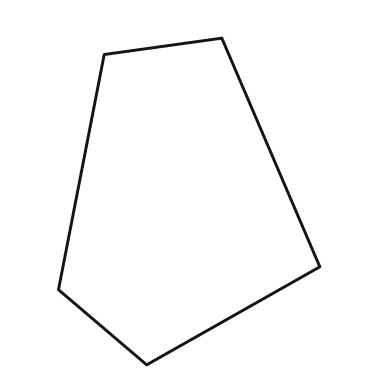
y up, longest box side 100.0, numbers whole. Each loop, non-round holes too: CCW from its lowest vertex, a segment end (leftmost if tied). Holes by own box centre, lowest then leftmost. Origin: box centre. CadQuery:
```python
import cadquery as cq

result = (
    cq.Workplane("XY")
    .moveTo(-13.0, -50.0)
    .lineTo(40.0, -20.0)
    .lineTo(10.0, 50.0)
    .lineTo(-26.0, 45.0)
    .lineTo(-40.0, -27.0)
    .close()
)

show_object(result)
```